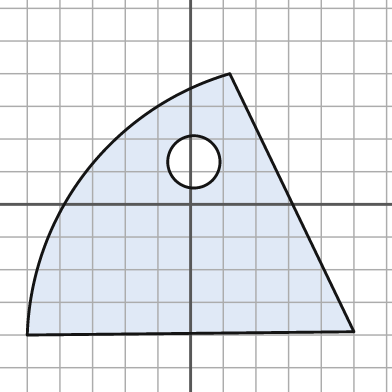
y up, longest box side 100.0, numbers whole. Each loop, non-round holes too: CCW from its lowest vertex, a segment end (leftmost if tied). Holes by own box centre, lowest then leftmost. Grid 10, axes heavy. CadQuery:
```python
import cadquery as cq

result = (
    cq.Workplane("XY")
    .moveTo(-50.0, -40.0)
    .lineTo(50.0, -39.0)
    .lineTo(12.0, 40.0)
    .threePointArc((-32.0, 10.0), (-50.0, -40.0))
    .close()
    .moveTo(1.0, 13.0)
    .circle(8.0)
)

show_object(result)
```